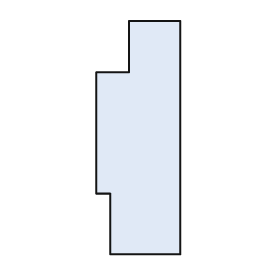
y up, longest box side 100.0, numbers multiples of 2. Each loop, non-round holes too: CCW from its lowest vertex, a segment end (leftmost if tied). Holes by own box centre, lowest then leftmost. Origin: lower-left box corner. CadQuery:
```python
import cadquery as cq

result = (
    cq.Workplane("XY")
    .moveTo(6.0, 0.0)
    .lineTo(36.0, 0.0)
    .lineTo(36.0, 100.0)
    .lineTo(14.0, 100.0)
    .lineTo(14.0, 78.0)
    .lineTo(0.0, 78.0)
    .lineTo(0.0, 26.0)
    .lineTo(6.0, 26.0)
    .close()
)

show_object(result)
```